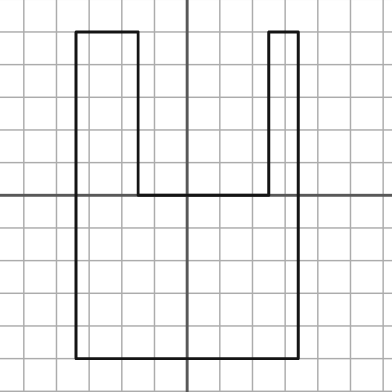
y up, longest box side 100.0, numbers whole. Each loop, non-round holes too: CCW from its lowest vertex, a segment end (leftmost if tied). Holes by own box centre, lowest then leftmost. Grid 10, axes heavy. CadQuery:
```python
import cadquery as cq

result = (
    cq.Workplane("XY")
    .moveTo(-34.0, -50.0)
    .lineTo(34.0, -50.0)
    .lineTo(34.0, 50.0)
    .lineTo(25.0, 50.0)
    .lineTo(25.0, 0.0)
    .lineTo(-15.0, 0.0)
    .lineTo(-15.0, 50.0)
    .lineTo(-34.0, 50.0)
    .close()
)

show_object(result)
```